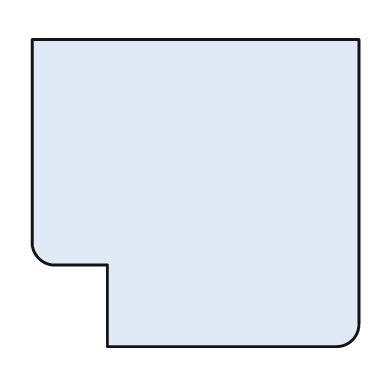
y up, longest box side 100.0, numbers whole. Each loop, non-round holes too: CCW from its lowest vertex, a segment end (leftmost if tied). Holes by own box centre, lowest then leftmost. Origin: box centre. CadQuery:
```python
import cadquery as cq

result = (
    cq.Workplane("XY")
    .moveTo(-27.0, -47.0)
    .lineTo(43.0, -47.0)
    .threePointArc((48.0, -45.0), (50.0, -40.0))
    .lineTo(50.0, 47.0)
    .lineTo(-50.0, 47.0)
    .lineTo(-50.0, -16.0)
    .threePointArc((-48.0, -20.0), (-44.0, -22.0))
    .lineTo(-27.0, -22.0)
    .close()
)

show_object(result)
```